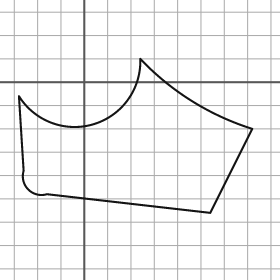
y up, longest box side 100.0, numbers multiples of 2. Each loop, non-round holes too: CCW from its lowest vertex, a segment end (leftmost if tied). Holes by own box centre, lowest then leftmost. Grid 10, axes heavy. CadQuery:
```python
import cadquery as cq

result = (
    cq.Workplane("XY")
    .moveTo(54.0, -56.0)
    .lineTo(72.0, -20.0)
    .threePointArc((46.0, -8.0), (24.0, 10.0))
    .threePointArc((4.0, -18.0), (-28.0, -6.0))
    .lineTo(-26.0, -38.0)
    .threePointArc((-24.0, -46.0), (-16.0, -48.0))
    .close()
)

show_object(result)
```